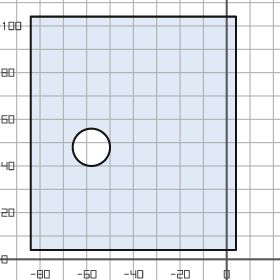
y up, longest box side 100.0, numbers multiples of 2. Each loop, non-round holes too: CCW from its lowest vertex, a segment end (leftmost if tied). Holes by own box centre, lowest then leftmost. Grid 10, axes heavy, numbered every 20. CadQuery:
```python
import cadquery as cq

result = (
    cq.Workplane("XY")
    .moveTo(-84.0, 4.0)
    .lineTo(4.0, 4.0)
    .lineTo(4.0, 104.0)
    .lineTo(-84.0, 104.0)
    .close()
    .moveTo(-58.0, 48.0)
    .circle(8.0)
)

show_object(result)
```